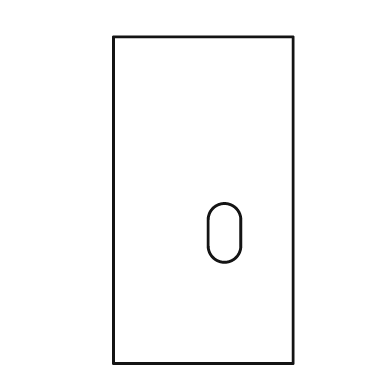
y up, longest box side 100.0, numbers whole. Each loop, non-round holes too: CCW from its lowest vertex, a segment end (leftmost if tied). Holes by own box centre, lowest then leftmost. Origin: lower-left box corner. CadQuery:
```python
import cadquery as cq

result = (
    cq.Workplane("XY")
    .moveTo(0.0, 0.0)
    .lineTo(55.0, 0.0)
    .lineTo(55.0, 100.0)
    .lineTo(0.0, 100.0)
    .close()
    .moveTo(29.0, 36.0)
    .threePointArc((34.0, 31.0), (39.0, 36.0))
    .lineTo(39.0, 44.0)
    .threePointArc((34.0, 49.0), (29.0, 44.0))
    .close()
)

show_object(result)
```